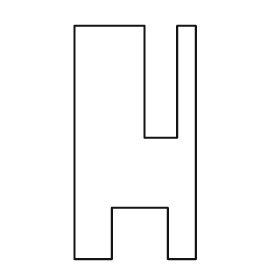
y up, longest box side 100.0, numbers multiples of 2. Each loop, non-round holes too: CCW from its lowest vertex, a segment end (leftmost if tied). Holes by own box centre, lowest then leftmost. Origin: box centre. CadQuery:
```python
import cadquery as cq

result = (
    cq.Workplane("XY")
    .moveTo(-26.0, -50.0)
    .lineTo(-10.0, -50.0)
    .lineTo(-10.0, -28.0)
    .lineTo(14.0, -28.0)
    .lineTo(14.0, -50.0)
    .lineTo(26.0, -50.0)
    .lineTo(26.0, 50.0)
    .lineTo(18.0, 50.0)
    .lineTo(18.0, 2.0)
    .lineTo(4.0, 2.0)
    .lineTo(4.0, 50.0)
    .lineTo(-26.0, 50.0)
    .close()
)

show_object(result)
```